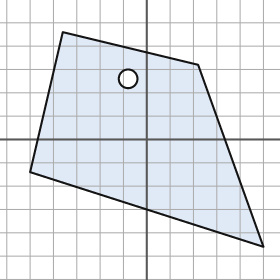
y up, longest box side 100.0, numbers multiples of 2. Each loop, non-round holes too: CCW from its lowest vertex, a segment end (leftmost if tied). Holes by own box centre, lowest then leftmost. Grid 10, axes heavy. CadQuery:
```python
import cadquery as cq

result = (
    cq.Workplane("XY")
    .moveTo(50.0, -46.0)
    .lineTo(22.0, 32.0)
    .lineTo(-36.0, 46.0)
    .lineTo(-50.0, -14.0)
    .close()
    .moveTo(-8.0, 26.0)
    .circle(4.0)
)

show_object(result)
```